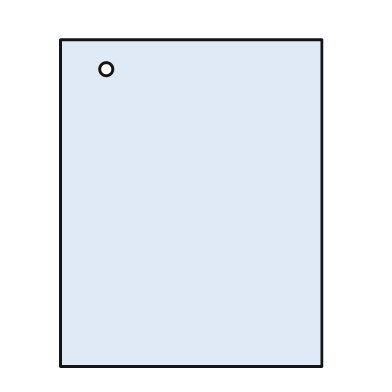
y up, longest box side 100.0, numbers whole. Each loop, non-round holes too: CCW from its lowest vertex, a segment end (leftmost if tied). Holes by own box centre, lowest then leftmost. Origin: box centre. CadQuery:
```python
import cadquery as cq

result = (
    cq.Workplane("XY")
    .moveTo(-40.0, -50.0)
    .lineTo(40.0, -50.0)
    .lineTo(40.0, 50.0)
    .lineTo(-40.0, 50.0)
    .close()
    .moveTo(-26.0, 41.0)
    .circle(2.0)
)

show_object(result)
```